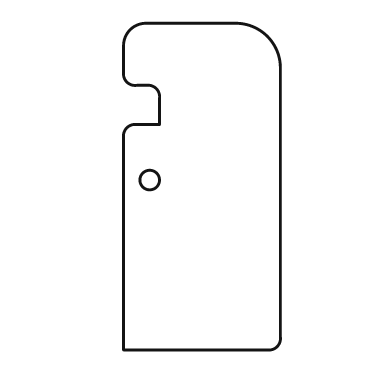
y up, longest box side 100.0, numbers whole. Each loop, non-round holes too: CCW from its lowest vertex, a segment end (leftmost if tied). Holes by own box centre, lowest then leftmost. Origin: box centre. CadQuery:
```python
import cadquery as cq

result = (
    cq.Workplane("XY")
    .moveTo(-24.0, -50.0)
    .lineTo(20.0, -50.0)
    .threePointArc((23.0, -49.0), (24.0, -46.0))
    .lineTo(24.0, 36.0)
    .threePointArc((20.0, 46.0), (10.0, 50.0))
    .lineTo(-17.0, 50.0)
    .threePointArc((-22.0, 48.0), (-24.0, 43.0))
    .lineTo(-24.0, 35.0)
    .threePointArc((-23.0, 32.0), (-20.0, 31.0))
    .lineTo(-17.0, 31.0)
    .threePointArc((-14.0, 30.0), (-13.0, 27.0))
    .lineTo(-13.0, 19.0)
    .lineTo(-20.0, 19.0)
    .threePointArc((-23.0, 18.0), (-24.0, 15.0))
    .close()
    .moveTo(-16.0, 2.0)
    .circle(3.0)
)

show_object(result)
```